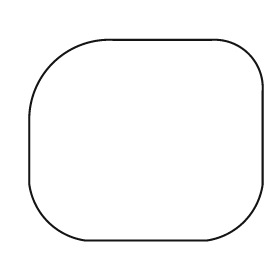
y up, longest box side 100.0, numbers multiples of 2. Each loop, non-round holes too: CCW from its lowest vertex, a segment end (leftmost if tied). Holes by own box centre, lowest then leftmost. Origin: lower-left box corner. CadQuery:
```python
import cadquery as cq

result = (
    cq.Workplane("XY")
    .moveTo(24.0, 0.0)
    .lineTo(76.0, 0.0)
    .threePointArc((92.0, 8.0), (100.0, 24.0))
    .lineTo(100.0, 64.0)
    .threePointArc((94.0, 80.0), (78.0, 86.0))
    .lineTo(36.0, 86.0)
    .threePointArc((10.0, 76.0), (0.0, 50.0))
    .lineTo(0.0, 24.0)
    .threePointArc((8.0, 8.0), (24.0, 0.0))
    .close()
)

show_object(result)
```